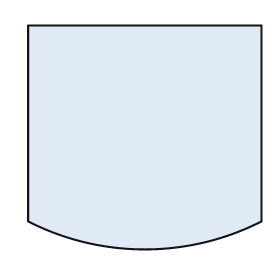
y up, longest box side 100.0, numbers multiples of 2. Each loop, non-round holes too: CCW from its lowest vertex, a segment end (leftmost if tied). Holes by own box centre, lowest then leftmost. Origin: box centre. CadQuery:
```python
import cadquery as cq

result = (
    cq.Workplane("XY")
    .moveTo(-50.0, -36.0)
    .threePointArc((0.0, -48.0), (50.0, -36.0))
    .lineTo(50.0, 48.0)
    .lineTo(-50.0, 48.0)
    .close()
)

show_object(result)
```